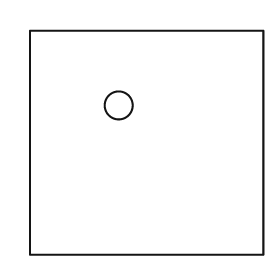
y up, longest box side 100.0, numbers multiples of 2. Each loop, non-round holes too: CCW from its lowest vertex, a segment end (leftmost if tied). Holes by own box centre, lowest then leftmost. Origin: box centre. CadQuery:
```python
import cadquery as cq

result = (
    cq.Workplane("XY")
    .moveTo(-50.0, -48.0)
    .lineTo(50.0, -48.0)
    .lineTo(50.0, 48.0)
    .lineTo(-50.0, 48.0)
    .close()
    .moveTo(-12.0, 16.0)
    .circle(6.0)
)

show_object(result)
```